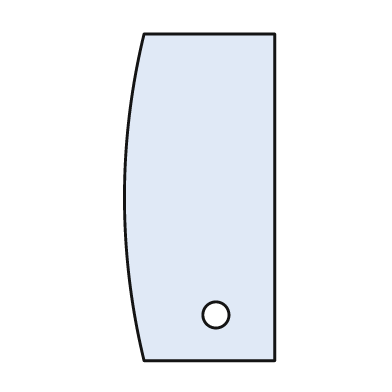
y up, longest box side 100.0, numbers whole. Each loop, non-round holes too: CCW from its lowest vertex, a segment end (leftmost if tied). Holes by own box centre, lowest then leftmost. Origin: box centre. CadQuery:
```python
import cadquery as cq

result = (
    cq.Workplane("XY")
    .moveTo(-17.0, -50.0)
    .lineTo(23.0, -50.0)
    .lineTo(23.0, 50.0)
    .lineTo(-17.0, 50.0)
    .threePointArc((-23.0, 0.0), (-17.0, -50.0))
    .close()
    .moveTo(5.0, -36.0)
    .circle(4.0)
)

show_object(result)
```